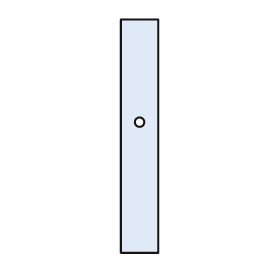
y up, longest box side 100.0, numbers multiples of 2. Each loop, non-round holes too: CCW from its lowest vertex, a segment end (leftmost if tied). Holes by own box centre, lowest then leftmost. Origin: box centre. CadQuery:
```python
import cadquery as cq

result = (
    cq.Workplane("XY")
    .moveTo(-8.0, -50.0)
    .lineTo(8.0, -50.0)
    .lineTo(8.0, 50.0)
    .lineTo(-8.0, 50.0)
    .close()
    .moveTo(0.0, 6.0)
    .circle(2.0)
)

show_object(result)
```